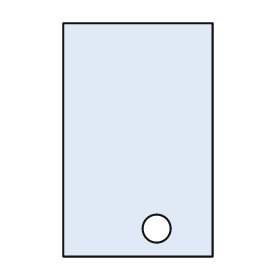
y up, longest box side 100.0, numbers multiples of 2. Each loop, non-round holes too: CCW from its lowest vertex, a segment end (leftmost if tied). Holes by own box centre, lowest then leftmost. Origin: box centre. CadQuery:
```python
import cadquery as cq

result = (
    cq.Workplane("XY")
    .moveTo(-32.0, -50.0)
    .lineTo(32.0, -50.0)
    .lineTo(32.0, 50.0)
    .lineTo(-32.0, 50.0)
    .close()
    .moveTo(8.0, -38.0)
    .circle(6.0)
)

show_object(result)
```